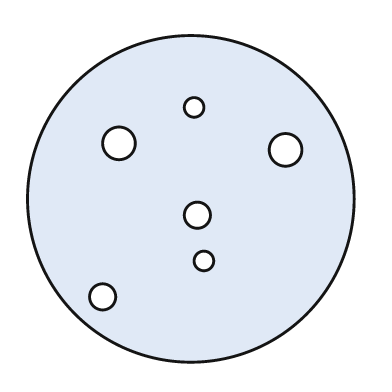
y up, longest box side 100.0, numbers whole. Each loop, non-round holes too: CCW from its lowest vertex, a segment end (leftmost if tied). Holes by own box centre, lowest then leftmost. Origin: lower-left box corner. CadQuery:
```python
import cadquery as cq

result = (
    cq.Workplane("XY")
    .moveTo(50.0, 50.0)
    .circle(50.0)
    .moveTo(23.0, 20.0)
    .circle(4.0)
    .moveTo(54.0, 31.0)
    .circle(3.0)
    .moveTo(52.0, 45.0)
    .circle(4.0)
    .moveTo(79.0, 65.0)
    .circle(5.0)
    .moveTo(28.0, 67.0)
    .circle(5.0)
    .moveTo(51.0, 78.0)
    .circle(3.0)
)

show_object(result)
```